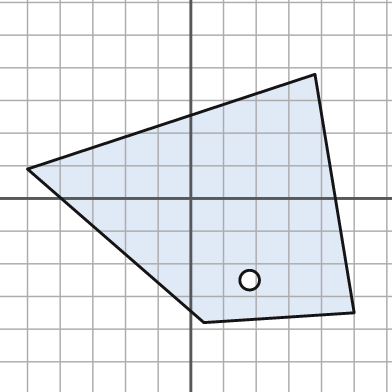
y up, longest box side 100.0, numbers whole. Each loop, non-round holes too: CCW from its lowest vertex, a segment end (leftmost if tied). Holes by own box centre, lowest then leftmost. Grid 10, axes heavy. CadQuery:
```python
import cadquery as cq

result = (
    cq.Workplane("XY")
    .moveTo(4.0, -38.0)
    .lineTo(50.0, -35.0)
    .lineTo(38.0, 38.0)
    .lineTo(-50.0, 9.0)
    .close()
    .moveTo(18.0, -25.0)
    .circle(3.0)
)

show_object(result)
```